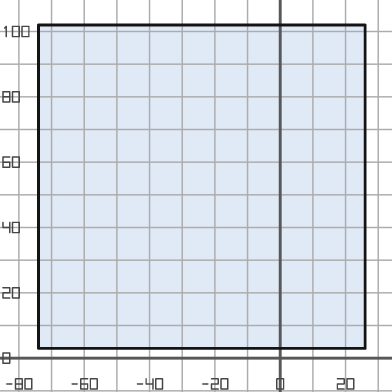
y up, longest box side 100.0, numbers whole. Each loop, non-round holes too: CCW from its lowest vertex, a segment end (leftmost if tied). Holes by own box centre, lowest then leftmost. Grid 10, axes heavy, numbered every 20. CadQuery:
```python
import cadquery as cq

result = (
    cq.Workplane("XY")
    .moveTo(-74.0, 3.0)
    .lineTo(26.0, 3.0)
    .lineTo(26.0, 102.0)
    .lineTo(-74.0, 102.0)
    .close()
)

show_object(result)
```